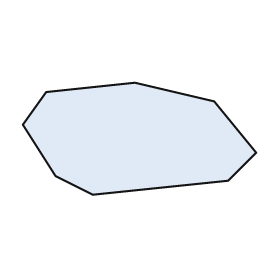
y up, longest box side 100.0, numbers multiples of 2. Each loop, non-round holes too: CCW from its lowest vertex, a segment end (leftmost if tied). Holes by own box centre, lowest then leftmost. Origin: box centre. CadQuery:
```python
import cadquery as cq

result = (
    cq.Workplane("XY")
    .moveTo(-20.0, -24.0)
    .lineTo(38.0, -18.0)
    .lineTo(50.0, -6.0)
    .lineTo(32.0, 16.0)
    .lineTo(-2.0, 24.0)
    .lineTo(-40.0, 20.0)
    .lineTo(-50.0, 6.0)
    .lineTo(-36.0, -16.0)
    .close()
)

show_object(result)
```